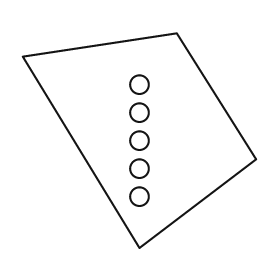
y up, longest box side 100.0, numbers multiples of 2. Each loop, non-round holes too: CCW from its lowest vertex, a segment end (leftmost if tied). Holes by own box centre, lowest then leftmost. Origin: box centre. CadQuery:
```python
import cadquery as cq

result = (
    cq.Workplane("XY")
    .moveTo(0.0, -46.0)
    .lineTo(50.0, -8.0)
    .lineTo(16.0, 46.0)
    .lineTo(-50.0, 36.0)
    .close()
    .moveTo(0.0, -24.0)
    .circle(4.0)
    .moveTo(0.0, -12.0)
    .circle(4.0)
    .moveTo(0.0, 0.0)
    .circle(4.0)
    .moveTo(0.0, 12.0)
    .circle(4.0)
    .moveTo(0.0, 24.0)
    .circle(4.0)
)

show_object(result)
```